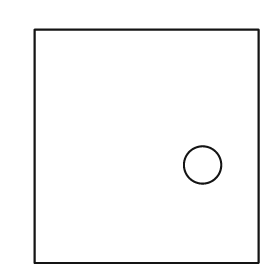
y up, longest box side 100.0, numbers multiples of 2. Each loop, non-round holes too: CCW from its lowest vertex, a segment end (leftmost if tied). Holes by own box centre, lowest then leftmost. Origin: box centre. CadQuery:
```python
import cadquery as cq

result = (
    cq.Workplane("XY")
    .moveTo(-48.0, -50.0)
    .lineTo(48.0, -50.0)
    .lineTo(48.0, 50.0)
    .lineTo(-48.0, 50.0)
    .close()
    .moveTo(24.0, -8.0)
    .circle(8.0)
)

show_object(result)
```